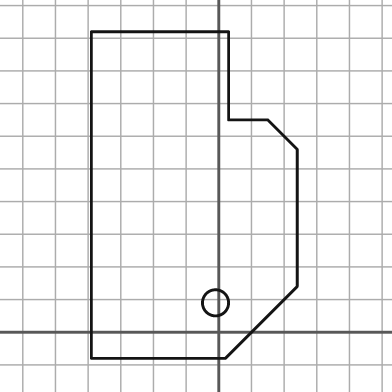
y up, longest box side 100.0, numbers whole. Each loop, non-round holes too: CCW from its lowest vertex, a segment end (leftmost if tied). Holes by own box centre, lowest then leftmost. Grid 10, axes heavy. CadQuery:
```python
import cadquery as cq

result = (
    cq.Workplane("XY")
    .moveTo(-39.0, -8.0)
    .lineTo(2.0, -8.0)
    .lineTo(24.0, 14.0)
    .lineTo(24.0, 56.0)
    .lineTo(15.0, 65.0)
    .lineTo(3.0, 65.0)
    .lineTo(3.0, 92.0)
    .lineTo(-39.0, 92.0)
    .close()
    .moveTo(-1.0, 9.0)
    .circle(4.0)
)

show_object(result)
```